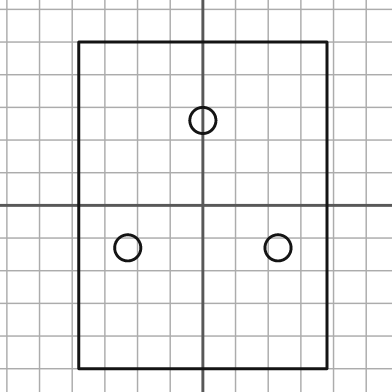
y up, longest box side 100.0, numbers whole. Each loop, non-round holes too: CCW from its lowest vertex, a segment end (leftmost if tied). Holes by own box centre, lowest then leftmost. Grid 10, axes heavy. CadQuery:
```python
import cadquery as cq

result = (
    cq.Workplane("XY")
    .moveTo(-38.0, -50.0)
    .lineTo(38.0, -50.0)
    .lineTo(38.0, 50.0)
    .lineTo(-38.0, 50.0)
    .close()
    .moveTo(-23.0, -13.0)
    .circle(4.0)
    .moveTo(23.0, -13.0)
    .circle(4.0)
    .moveTo(0.0, 26.0)
    .circle(4.0)
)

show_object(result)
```